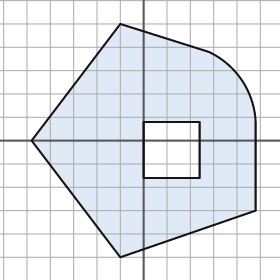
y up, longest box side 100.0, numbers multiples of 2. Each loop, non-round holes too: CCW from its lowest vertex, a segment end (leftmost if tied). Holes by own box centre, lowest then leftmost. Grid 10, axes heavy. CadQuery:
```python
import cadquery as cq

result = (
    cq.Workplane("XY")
    .moveTo(-10.0, -50.0)
    .lineTo(48.0, -30.0)
    .lineTo(48.0, 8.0)
    .threePointArc((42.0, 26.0), (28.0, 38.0))
    .lineTo(-10.0, 50.0)
    .lineTo(-48.0, 0.0)
    .close()
    .moveTo(0.0, -16.0)
    .lineTo(24.0, -16.0)
    .lineTo(24.0, 8.0)
    .lineTo(0.0, 8.0)
    .close()
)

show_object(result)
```